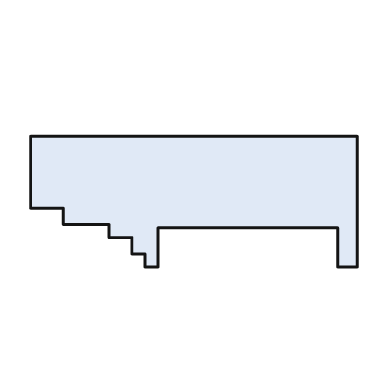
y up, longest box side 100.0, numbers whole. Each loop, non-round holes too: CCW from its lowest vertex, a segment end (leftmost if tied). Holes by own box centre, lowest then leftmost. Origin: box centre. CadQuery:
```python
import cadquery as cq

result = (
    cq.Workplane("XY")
    .moveTo(-15.0, -20.0)
    .lineTo(-11.0, -20.0)
    .lineTo(-11.0, -8.0)
    .lineTo(44.0, -8.0)
    .lineTo(44.0, -20.0)
    .lineTo(50.0, -20.0)
    .lineTo(50.0, 20.0)
    .lineTo(-50.0, 20.0)
    .lineTo(-50.0, -2.0)
    .lineTo(-40.0, -2.0)
    .lineTo(-40.0, -7.0)
    .lineTo(-26.0, -7.0)
    .lineTo(-26.0, -11.0)
    .lineTo(-19.0, -11.0)
    .lineTo(-19.0, -16.0)
    .lineTo(-15.0, -16.0)
    .close()
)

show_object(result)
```